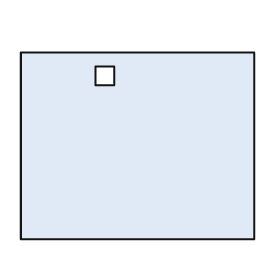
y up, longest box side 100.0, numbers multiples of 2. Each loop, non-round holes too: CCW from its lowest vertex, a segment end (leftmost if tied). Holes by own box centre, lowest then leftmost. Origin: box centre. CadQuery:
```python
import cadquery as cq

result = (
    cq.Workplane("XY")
    .moveTo(-50.0, -40.0)
    .lineTo(50.0, -40.0)
    .lineTo(50.0, 40.0)
    .lineTo(-50.0, 40.0)
    .close()
    .moveTo(-18.0, 26.0)
    .lineTo(-10.0, 26.0)
    .lineTo(-10.0, 34.0)
    .lineTo(-18.0, 34.0)
    .close()
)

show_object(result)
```